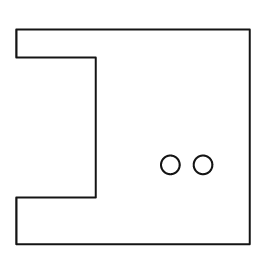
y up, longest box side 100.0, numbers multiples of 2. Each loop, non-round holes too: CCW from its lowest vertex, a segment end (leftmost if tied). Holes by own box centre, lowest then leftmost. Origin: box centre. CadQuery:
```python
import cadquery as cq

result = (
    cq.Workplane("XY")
    .moveTo(-50.0, -46.0)
    .lineTo(50.0, -46.0)
    .lineTo(50.0, 46.0)
    .lineTo(-50.0, 46.0)
    .lineTo(-50.0, 34.0)
    .lineTo(-16.0, 34.0)
    .lineTo(-16.0, -26.0)
    .lineTo(-50.0, -26.0)
    .close()
    .moveTo(16.0, -12.0)
    .circle(4.0)
    .moveTo(30.0, -12.0)
    .circle(4.0)
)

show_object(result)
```